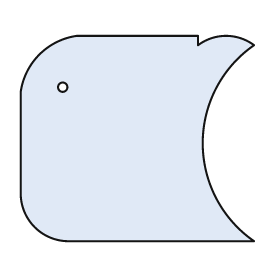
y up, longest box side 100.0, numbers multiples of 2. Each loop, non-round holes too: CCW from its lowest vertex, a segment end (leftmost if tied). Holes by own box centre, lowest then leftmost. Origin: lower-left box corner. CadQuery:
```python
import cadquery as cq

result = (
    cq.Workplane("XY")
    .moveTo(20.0, 0.0)
    .lineTo(100.0, 0.0)
    .threePointArc((78.0, 42.0), (100.0, 84.0))
    .threePointArc((88.0, 88.0), (76.0, 84.0))
    .lineTo(76.0, 88.0)
    .lineTo(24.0, 88.0)
    .threePointArc((8.0, 80.0), (0.0, 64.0))
    .lineTo(0.0, 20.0)
    .threePointArc((6.0, 6.0), (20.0, 0.0))
    .close()
    .moveTo(18.0, 66.0)
    .circle(2.0)
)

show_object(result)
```